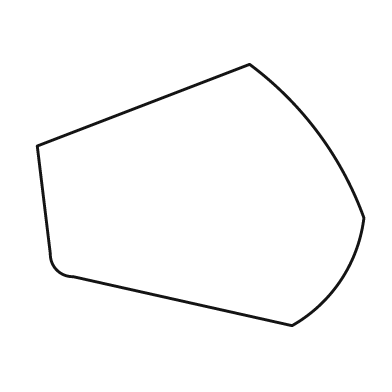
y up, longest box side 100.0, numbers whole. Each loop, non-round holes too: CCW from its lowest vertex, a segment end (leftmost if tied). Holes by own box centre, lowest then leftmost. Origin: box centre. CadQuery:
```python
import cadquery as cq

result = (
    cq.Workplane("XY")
    .moveTo(28.0, -40.0)
    .threePointArc((43.0, -26.0), (50.0, -7.0))
    .threePointArc((36.0, 19.0), (15.0, 40.0))
    .lineTo(-50.0, 15.0)
    .lineTo(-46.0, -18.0)
    .threePointArc((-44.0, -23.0), (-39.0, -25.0))
    .close()
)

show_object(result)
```